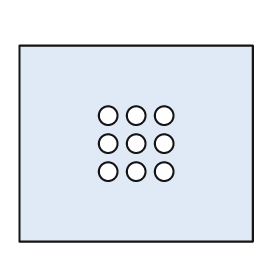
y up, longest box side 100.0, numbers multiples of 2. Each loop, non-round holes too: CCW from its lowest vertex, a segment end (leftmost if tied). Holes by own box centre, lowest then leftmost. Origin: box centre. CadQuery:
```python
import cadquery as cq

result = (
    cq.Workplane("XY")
    .moveTo(-50.0, -42.0)
    .lineTo(50.0, -42.0)
    .lineTo(50.0, 42.0)
    .lineTo(-50.0, 42.0)
    .close()
    .moveTo(-12.0, -12.0)
    .circle(4.0)
    .moveTo(0.0, -12.0)
    .circle(4.0)
    .moveTo(12.0, -12.0)
    .circle(4.0)
    .moveTo(-12.0, 0.0)
    .circle(4.0)
    .moveTo(0.0, 0.0)
    .circle(4.0)
    .moveTo(12.0, 0.0)
    .circle(4.0)
    .moveTo(-12.0, 12.0)
    .circle(4.0)
    .moveTo(0.0, 12.0)
    .circle(4.0)
    .moveTo(12.0, 12.0)
    .circle(4.0)
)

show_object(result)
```